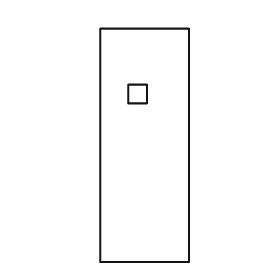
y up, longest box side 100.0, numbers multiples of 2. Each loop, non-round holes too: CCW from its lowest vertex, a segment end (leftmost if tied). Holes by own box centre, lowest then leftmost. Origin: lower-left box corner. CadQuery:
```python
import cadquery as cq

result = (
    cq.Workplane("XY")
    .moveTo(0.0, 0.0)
    .lineTo(38.0, 0.0)
    .lineTo(38.0, 100.0)
    .lineTo(0.0, 100.0)
    .close()
    .moveTo(12.0, 68.0)
    .lineTo(20.0, 68.0)
    .lineTo(20.0, 76.0)
    .lineTo(12.0, 76.0)
    .close()
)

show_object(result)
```